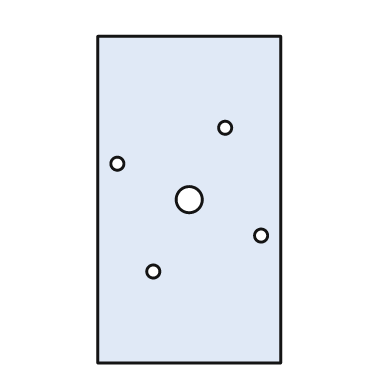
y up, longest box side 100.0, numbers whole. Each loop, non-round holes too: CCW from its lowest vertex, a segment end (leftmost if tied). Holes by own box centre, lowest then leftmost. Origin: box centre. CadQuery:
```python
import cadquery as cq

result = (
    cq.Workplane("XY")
    .moveTo(-28.0, -50.0)
    .lineTo(28.0, -50.0)
    .lineTo(28.0, 50.0)
    .lineTo(-28.0, 50.0)
    .close()
    .moveTo(-11.0, -22.0)
    .circle(2.0)
    .moveTo(22.0, -11.0)
    .circle(2.0)
    .moveTo(0.0, 0.0)
    .circle(4.0)
    .moveTo(-22.0, 11.0)
    .circle(2.0)
    .moveTo(11.0, 22.0)
    .circle(2.0)
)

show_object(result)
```